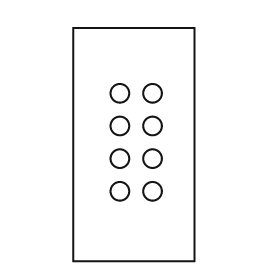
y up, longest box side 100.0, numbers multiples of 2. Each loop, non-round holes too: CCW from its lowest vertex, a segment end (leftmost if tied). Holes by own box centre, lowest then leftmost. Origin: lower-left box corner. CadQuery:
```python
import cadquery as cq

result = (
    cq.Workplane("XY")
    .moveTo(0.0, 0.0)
    .lineTo(52.0, 0.0)
    .lineTo(52.0, 100.0)
    .lineTo(0.0, 100.0)
    .close()
    .moveTo(20.0, 30.0)
    .circle(4.0)
    .moveTo(34.0, 30.0)
    .circle(4.0)
    .moveTo(20.0, 44.0)
    .circle(4.0)
    .moveTo(34.0, 44.0)
    .circle(4.0)
    .moveTo(20.0, 58.0)
    .circle(4.0)
    .moveTo(34.0, 58.0)
    .circle(4.0)
    .moveTo(20.0, 72.0)
    .circle(4.0)
    .moveTo(34.0, 72.0)
    .circle(4.0)
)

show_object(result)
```